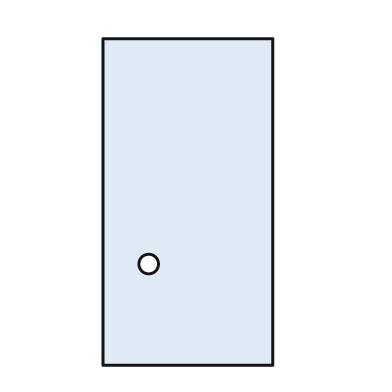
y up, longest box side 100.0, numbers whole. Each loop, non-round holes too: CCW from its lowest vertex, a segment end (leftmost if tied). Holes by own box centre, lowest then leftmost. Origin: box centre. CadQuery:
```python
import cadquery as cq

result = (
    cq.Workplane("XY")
    .moveTo(-26.0, -50.0)
    .lineTo(26.0, -50.0)
    .lineTo(26.0, 50.0)
    .lineTo(-26.0, 50.0)
    .close()
    .moveTo(-12.0, -19.0)
    .circle(3.0)
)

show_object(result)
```